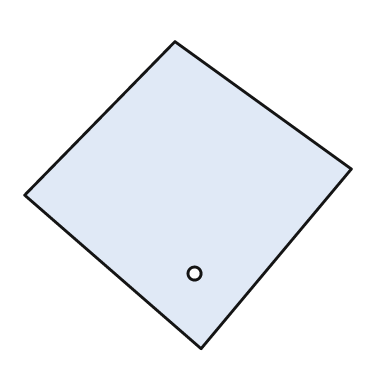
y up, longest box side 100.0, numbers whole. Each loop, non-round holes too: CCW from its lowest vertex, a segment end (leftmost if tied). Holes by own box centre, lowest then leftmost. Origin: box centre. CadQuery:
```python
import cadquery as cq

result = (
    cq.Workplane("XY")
    .moveTo(4.0, -47.0)
    .lineTo(50.0, 8.0)
    .lineTo(-4.0, 47.0)
    .lineTo(-50.0, 0.0)
    .close()
    .moveTo(2.0, -24.0)
    .circle(2.0)
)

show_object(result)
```